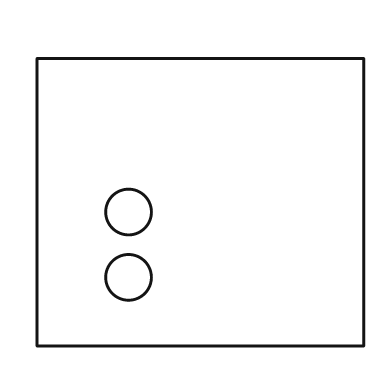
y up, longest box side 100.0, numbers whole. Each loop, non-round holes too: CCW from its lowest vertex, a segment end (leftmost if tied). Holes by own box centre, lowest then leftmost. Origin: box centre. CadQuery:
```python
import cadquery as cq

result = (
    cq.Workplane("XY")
    .moveTo(-50.0, -44.0)
    .lineTo(50.0, -44.0)
    .lineTo(50.0, 44.0)
    .lineTo(-50.0, 44.0)
    .close()
    .moveTo(-22.0, -23.0)
    .circle(7.0)
    .moveTo(-22.0, -3.0)
    .circle(7.0)
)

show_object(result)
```